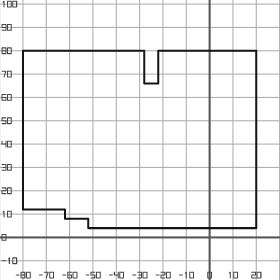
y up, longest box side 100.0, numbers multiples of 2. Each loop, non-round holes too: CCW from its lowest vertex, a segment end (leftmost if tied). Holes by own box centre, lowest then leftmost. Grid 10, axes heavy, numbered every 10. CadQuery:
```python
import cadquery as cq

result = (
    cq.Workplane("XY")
    .moveTo(-52.0, 4.0)
    .lineTo(20.0, 4.0)
    .lineTo(20.0, 80.0)
    .lineTo(-22.0, 80.0)
    .lineTo(-22.0, 66.0)
    .lineTo(-28.0, 66.0)
    .lineTo(-28.0, 80.0)
    .lineTo(-80.0, 80.0)
    .lineTo(-80.0, 12.0)
    .lineTo(-62.0, 12.0)
    .lineTo(-62.0, 8.0)
    .lineTo(-52.0, 8.0)
    .close()
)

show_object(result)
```